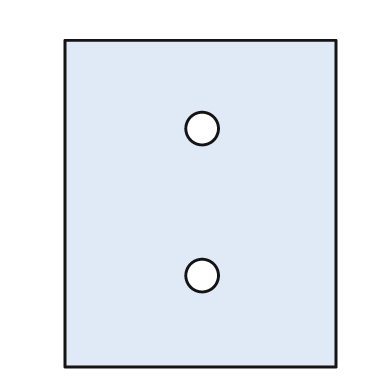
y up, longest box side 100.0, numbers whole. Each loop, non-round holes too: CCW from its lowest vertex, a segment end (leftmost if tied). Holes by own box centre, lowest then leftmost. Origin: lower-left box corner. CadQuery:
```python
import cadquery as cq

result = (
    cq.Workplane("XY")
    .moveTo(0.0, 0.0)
    .lineTo(83.0, 0.0)
    .lineTo(83.0, 100.0)
    .lineTo(0.0, 100.0)
    .close()
    .moveTo(42.0, 28.0)
    .circle(5.0)
    .moveTo(42.0, 73.0)
    .circle(5.0)
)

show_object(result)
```